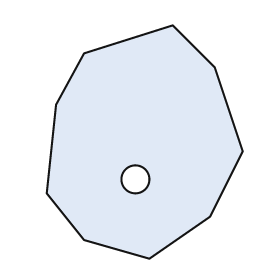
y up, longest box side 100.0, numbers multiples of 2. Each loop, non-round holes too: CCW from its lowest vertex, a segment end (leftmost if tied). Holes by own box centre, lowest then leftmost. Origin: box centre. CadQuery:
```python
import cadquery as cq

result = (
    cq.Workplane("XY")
    .moveTo(2.0, -50.0)
    .lineTo(28.0, -32.0)
    .lineTo(42.0, -4.0)
    .lineTo(30.0, 32.0)
    .lineTo(12.0, 50.0)
    .lineTo(-26.0, 38.0)
    .lineTo(-38.0, 16.0)
    .lineTo(-42.0, -22.0)
    .lineTo(-26.0, -42.0)
    .close()
    .moveTo(-4.0, -16.0)
    .circle(6.0)
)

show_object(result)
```